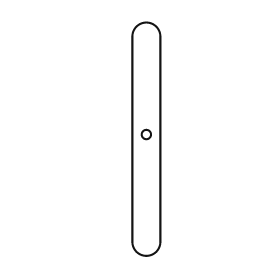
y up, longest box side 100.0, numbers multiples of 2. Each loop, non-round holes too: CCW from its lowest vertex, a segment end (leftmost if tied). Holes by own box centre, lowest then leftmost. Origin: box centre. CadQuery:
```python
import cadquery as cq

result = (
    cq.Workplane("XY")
    .moveTo(-6.0, -44.0)
    .threePointArc((0.0, -50.0), (6.0, -44.0))
    .lineTo(6.0, 44.0)
    .threePointArc((0.0, 50.0), (-6.0, 44.0))
    .close()
    .moveTo(0.0, 2.0)
    .circle(2.0)
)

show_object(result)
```